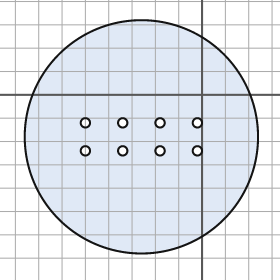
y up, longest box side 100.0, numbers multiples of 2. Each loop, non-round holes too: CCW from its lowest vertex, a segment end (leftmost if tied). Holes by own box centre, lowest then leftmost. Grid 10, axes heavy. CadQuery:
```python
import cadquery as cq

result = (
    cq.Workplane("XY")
    .moveTo(-26.0, -18.0)
    .circle(50.0)
    .moveTo(-50.0, -24.0)
    .circle(2.0)
    .moveTo(-34.0, -24.0)
    .circle(2.0)
    .moveTo(-18.0, -24.0)
    .circle(2.0)
    .moveTo(-2.0, -24.0)
    .circle(2.0)
    .moveTo(-50.0, -12.0)
    .circle(2.0)
    .moveTo(-34.0, -12.0)
    .circle(2.0)
    .moveTo(-18.0, -12.0)
    .circle(2.0)
    .moveTo(-2.0, -12.0)
    .circle(2.0)
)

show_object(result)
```